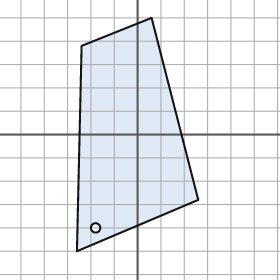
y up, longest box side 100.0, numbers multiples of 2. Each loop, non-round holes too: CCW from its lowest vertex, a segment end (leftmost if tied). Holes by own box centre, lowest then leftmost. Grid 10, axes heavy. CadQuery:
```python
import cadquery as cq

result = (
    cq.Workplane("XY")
    .moveTo(-26.0, -50.0)
    .lineTo(26.0, -28.0)
    .lineTo(6.0, 50.0)
    .lineTo(-24.0, 38.0)
    .close()
    .moveTo(-18.0, -40.0)
    .circle(2.0)
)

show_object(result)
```